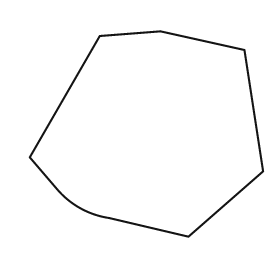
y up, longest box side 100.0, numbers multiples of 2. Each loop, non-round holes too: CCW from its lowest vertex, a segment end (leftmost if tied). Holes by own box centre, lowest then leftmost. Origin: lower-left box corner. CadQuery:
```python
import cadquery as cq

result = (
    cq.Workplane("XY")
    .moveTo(68.0, 0.0)
    .lineTo(100.0, 28.0)
    .lineTo(92.0, 80.0)
    .lineTo(56.0, 88.0)
    .lineTo(30.0, 86.0)
    .lineTo(0.0, 34.0)
    .lineTo(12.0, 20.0)
    .threePointArc((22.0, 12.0), (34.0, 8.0))
    .close()
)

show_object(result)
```